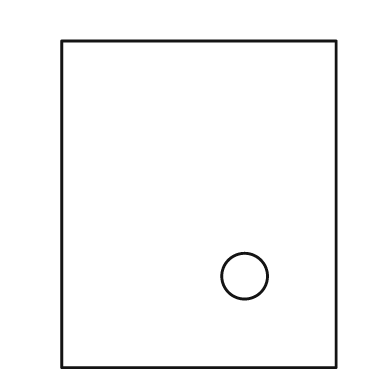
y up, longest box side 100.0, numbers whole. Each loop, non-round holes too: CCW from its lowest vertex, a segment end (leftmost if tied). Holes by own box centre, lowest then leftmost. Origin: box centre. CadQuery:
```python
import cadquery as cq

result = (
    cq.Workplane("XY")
    .moveTo(-42.0, -50.0)
    .lineTo(42.0, -50.0)
    .lineTo(42.0, 50.0)
    .lineTo(-42.0, 50.0)
    .close()
    .moveTo(14.0, -22.0)
    .circle(7.0)
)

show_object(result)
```